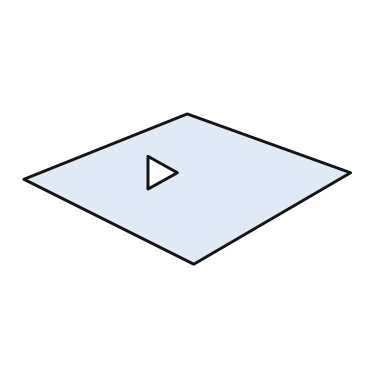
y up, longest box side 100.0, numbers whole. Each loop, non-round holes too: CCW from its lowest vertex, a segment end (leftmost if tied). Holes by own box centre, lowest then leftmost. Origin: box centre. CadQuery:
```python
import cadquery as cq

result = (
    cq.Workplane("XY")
    .moveTo(2.0, -23.0)
    .lineTo(50.0, 5.0)
    .lineTo(0.0, 23.0)
    .lineTo(-50.0, 3.0)
    .close()
    .moveTo(-12.0, 0.0)
    .lineTo(-3.0, 5.0)
    .lineTo(-12.0, 10.0)
    .close()
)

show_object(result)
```